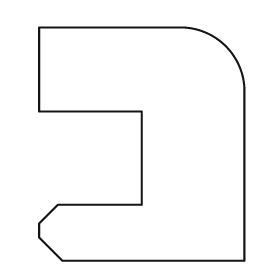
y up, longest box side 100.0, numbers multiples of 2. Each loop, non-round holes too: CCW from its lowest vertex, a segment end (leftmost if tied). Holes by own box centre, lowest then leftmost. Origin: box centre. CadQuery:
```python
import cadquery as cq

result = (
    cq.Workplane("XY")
    .moveTo(-34.0, -50.0)
    .lineTo(44.0, -50.0)
    .lineTo(44.0, 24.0)
    .threePointArc((36.0, 42.0), (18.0, 50.0))
    .lineTo(-44.0, 50.0)
    .lineTo(-44.0, 14.0)
    .lineTo(0.0, 14.0)
    .lineTo(0.0, -26.0)
    .lineTo(-36.0, -26.0)
    .lineTo(-44.0, -34.0)
    .lineTo(-44.0, -40.0)
    .close()
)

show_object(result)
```